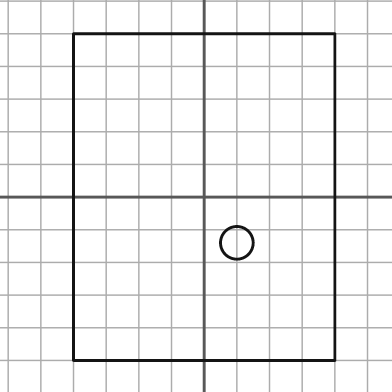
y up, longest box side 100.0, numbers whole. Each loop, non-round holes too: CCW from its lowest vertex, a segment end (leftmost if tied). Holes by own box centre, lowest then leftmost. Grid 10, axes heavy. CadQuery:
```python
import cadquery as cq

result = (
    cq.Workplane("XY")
    .moveTo(-40.0, -50.0)
    .lineTo(40.0, -50.0)
    .lineTo(40.0, 50.0)
    .lineTo(-40.0, 50.0)
    .close()
    .moveTo(10.0, -14.0)
    .circle(5.0)
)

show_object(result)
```